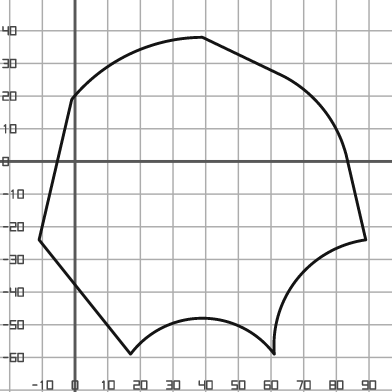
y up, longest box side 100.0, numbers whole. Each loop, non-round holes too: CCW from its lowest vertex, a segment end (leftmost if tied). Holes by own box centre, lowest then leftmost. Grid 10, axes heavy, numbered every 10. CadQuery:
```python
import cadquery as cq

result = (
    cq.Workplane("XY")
    .moveTo(17.0, -59.0)
    .threePointArc((39.0, -48.0), (61.0, -59.0))
    .threePointArc((68.0, -36.0), (89.0, -24.0))
    .lineTo(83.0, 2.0)
    .threePointArc((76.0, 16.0), (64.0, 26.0))
    .lineTo(39.0, 38.0)
    .threePointArc((17.0, 33.0), (-1.0, 19.0))
    .lineTo(-11.0, -24.0)
    .close()
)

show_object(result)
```